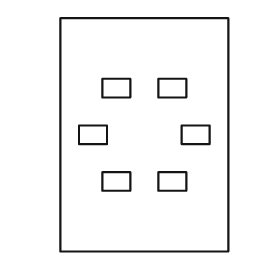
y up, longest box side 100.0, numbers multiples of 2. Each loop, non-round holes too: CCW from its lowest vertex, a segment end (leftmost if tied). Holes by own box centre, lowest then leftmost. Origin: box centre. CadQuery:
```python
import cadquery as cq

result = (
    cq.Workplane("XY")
    .moveTo(-36.0, -50.0)
    .lineTo(36.0, -50.0)
    .lineTo(36.0, 50.0)
    .lineTo(-36.0, 50.0)
    .close()
    .moveTo(-18.0, -24.0)
    .lineTo(-6.0, -24.0)
    .lineTo(-6.0, -16.0)
    .lineTo(-18.0, -16.0)
    .close()
    .moveTo(6.0, -24.0)
    .lineTo(18.0, -24.0)
    .lineTo(18.0, -16.0)
    .lineTo(6.0, -16.0)
    .close()
    .moveTo(-28.0, -4.0)
    .lineTo(-16.0, -4.0)
    .lineTo(-16.0, 4.0)
    .lineTo(-28.0, 4.0)
    .close()
    .moveTo(16.0, -4.0)
    .lineTo(28.0, -4.0)
    .lineTo(28.0, 4.0)
    .lineTo(16.0, 4.0)
    .close()
    .moveTo(-18.0, 16.0)
    .lineTo(-6.0, 16.0)
    .lineTo(-6.0, 24.0)
    .lineTo(-18.0, 24.0)
    .close()
    .moveTo(6.0, 16.0)
    .lineTo(18.0, 16.0)
    .lineTo(18.0, 24.0)
    .lineTo(6.0, 24.0)
    .close()
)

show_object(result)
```